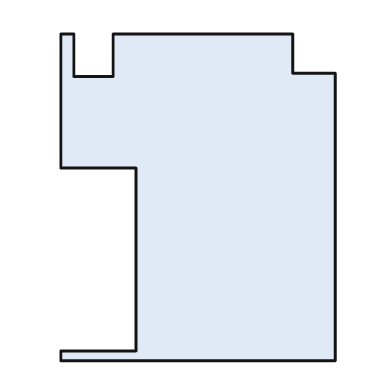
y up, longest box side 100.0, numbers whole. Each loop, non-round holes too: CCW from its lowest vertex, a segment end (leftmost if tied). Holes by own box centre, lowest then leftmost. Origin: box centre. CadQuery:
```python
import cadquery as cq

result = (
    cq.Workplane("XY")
    .moveTo(-42.0, -50.0)
    .lineTo(42.0, -50.0)
    .lineTo(42.0, 38.0)
    .lineTo(29.0, 38.0)
    .lineTo(29.0, 50.0)
    .lineTo(-26.0, 50.0)
    .lineTo(-26.0, 37.0)
    .lineTo(-38.0, 37.0)
    .lineTo(-38.0, 50.0)
    .lineTo(-42.0, 50.0)
    .lineTo(-42.0, 9.0)
    .lineTo(-19.0, 9.0)
    .lineTo(-19.0, -47.0)
    .lineTo(-42.0, -47.0)
    .close()
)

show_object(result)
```